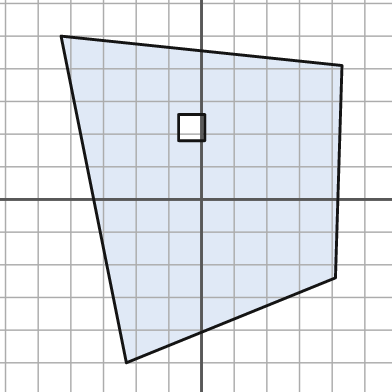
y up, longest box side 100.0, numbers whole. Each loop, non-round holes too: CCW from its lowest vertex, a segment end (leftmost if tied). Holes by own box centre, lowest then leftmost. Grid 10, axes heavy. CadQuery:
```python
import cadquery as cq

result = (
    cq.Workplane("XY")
    .moveTo(-23.0, -50.0)
    .lineTo(41.0, -24.0)
    .lineTo(43.0, 41.0)
    .lineTo(-43.0, 50.0)
    .close()
    .moveTo(-7.0, 18.0)
    .lineTo(1.0, 18.0)
    .lineTo(1.0, 26.0)
    .lineTo(-7.0, 26.0)
    .close()
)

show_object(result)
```